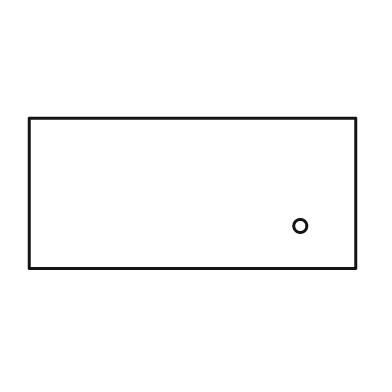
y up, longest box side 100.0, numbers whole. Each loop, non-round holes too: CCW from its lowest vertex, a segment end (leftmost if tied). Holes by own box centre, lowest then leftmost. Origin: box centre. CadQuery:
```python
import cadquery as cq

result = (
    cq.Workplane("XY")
    .moveTo(-50.0, -23.0)
    .lineTo(50.0, -23.0)
    .lineTo(50.0, 23.0)
    .lineTo(-50.0, 23.0)
    .close()
    .moveTo(33.0, -10.0)
    .circle(2.0)
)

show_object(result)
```